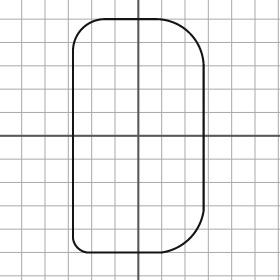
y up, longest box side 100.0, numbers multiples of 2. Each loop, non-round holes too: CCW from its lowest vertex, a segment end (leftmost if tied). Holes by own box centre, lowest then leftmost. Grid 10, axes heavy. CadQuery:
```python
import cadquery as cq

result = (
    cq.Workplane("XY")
    .moveTo(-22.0, -50.0)
    .lineTo(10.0, -50.0)
    .threePointArc((22.0, -44.0), (28.0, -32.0))
    .lineTo(28.0, 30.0)
    .threePointArc((22.0, 44.0), (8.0, 50.0))
    .lineTo(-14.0, 50.0)
    .threePointArc((-24.0, 46.0), (-28.0, 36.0))
    .lineTo(-28.0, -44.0)
    .threePointArc((-26.0, -48.0), (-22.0, -50.0))
    .close()
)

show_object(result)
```